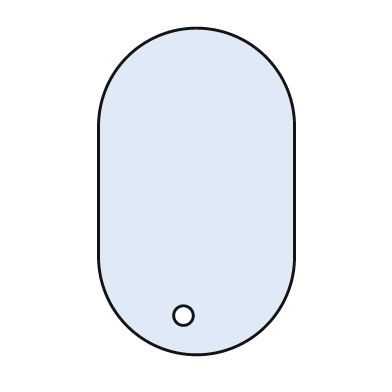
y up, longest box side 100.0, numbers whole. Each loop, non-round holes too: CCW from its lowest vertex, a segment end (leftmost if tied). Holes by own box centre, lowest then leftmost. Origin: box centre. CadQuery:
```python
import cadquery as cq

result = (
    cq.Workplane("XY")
    .moveTo(-30.0, -20.0)
    .threePointArc((0.0, -50.0), (30.0, -20.0))
    .lineTo(30.0, 20.0)
    .threePointArc((0.0, 50.0), (-30.0, 20.0))
    .close()
    .moveTo(-4.0, -38.0)
    .circle(3.0)
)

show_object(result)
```